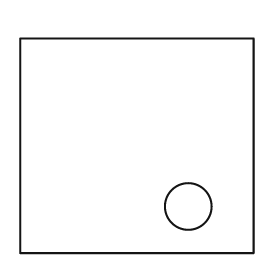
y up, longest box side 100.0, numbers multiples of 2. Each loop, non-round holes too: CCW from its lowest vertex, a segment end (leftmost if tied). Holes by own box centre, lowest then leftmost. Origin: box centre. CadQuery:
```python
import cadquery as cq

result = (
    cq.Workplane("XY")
    .moveTo(-50.0, -46.0)
    .lineTo(50.0, -46.0)
    .lineTo(50.0, 46.0)
    .lineTo(-50.0, 46.0)
    .close()
    .moveTo(22.0, -26.0)
    .circle(10.0)
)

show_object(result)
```